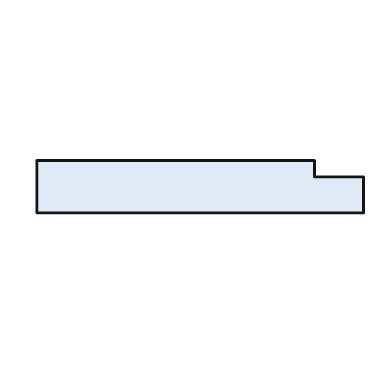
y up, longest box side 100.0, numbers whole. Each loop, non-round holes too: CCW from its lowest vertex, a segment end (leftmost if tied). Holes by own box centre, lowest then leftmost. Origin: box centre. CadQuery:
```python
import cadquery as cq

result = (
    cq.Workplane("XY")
    .moveTo(-50.0, -8.0)
    .lineTo(50.0, -8.0)
    .lineTo(50.0, 3.0)
    .lineTo(35.0, 3.0)
    .lineTo(35.0, 8.0)
    .lineTo(-50.0, 8.0)
    .close()
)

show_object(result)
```